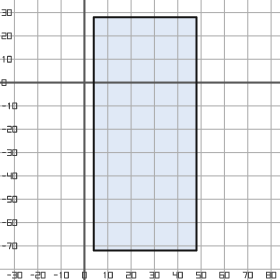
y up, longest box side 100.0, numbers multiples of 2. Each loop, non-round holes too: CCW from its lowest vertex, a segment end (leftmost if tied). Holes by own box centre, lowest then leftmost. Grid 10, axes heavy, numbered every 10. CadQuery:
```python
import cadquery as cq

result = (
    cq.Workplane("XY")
    .moveTo(4.0, -72.0)
    .lineTo(48.0, -72.0)
    .lineTo(48.0, 28.0)
    .lineTo(4.0, 28.0)
    .close()
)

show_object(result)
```